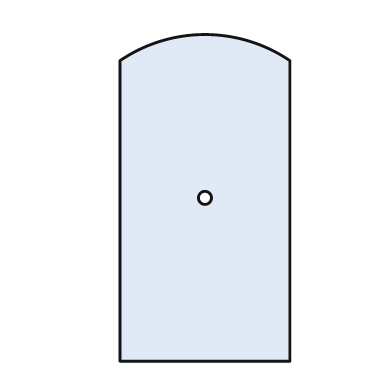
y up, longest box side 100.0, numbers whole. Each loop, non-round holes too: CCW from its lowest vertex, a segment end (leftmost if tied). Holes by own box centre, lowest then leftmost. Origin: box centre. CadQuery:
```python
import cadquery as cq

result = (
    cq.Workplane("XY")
    .moveTo(-26.0, -50.0)
    .lineTo(26.0, -50.0)
    .lineTo(26.0, 42.0)
    .threePointArc((0.0, 50.0), (-26.0, 42.0))
    .close()
    .moveTo(0.0, 0.0)
    .circle(2.0)
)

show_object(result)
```